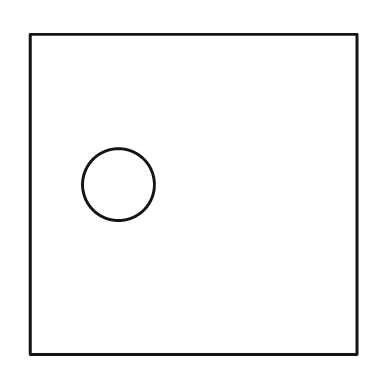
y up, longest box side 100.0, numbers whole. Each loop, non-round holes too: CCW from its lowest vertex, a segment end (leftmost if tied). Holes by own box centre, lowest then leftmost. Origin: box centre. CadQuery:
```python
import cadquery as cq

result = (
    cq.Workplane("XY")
    .moveTo(-50.0, -49.0)
    .lineTo(50.0, -49.0)
    .lineTo(50.0, 49.0)
    .lineTo(-50.0, 49.0)
    .close()
    .moveTo(-23.0, 3.0)
    .circle(11.0)
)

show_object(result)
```